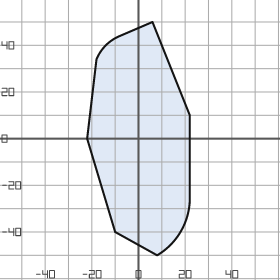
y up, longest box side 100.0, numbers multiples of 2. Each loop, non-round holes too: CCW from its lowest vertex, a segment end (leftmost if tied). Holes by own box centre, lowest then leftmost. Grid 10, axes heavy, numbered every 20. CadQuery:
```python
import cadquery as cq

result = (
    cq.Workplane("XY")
    .moveTo(8.0, -50.0)
    .threePointArc((18.0, -40.0), (22.0, -26.0))
    .lineTo(22.0, 10.0)
    .lineTo(6.0, 50.0)
    .lineTo(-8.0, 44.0)
    .threePointArc((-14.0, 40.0), (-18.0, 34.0))
    .lineTo(-22.0, 0.0)
    .lineTo(-10.0, -40.0)
    .close()
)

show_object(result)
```